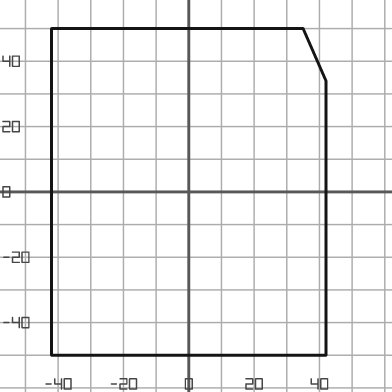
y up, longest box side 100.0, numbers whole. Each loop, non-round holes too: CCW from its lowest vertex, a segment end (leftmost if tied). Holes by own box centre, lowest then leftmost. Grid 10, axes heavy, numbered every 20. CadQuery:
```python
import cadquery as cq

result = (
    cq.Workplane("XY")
    .moveTo(-42.0, -50.0)
    .lineTo(42.0, -50.0)
    .lineTo(42.0, 34.0)
    .lineTo(35.0, 50.0)
    .lineTo(-42.0, 50.0)
    .close()
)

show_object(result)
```